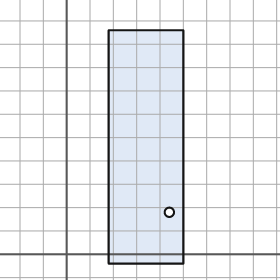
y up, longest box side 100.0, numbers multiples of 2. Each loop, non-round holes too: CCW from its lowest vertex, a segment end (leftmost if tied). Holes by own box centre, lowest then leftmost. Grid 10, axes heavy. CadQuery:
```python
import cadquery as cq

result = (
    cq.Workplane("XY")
    .moveTo(18.0, -4.0)
    .lineTo(50.0, -4.0)
    .lineTo(50.0, 96.0)
    .lineTo(18.0, 96.0)
    .close()
    .moveTo(44.0, 18.0)
    .circle(2.0)
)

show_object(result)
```